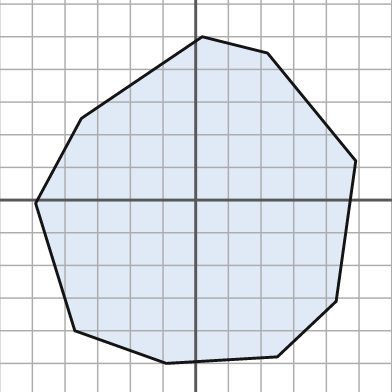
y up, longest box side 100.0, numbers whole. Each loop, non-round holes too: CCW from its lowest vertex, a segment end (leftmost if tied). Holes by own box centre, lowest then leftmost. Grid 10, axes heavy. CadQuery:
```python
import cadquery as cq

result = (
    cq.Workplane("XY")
    .moveTo(-9.0, -50.0)
    .lineTo(25.0, -48.0)
    .lineTo(43.0, -31.0)
    .lineTo(49.0, 12.0)
    .lineTo(22.0, 45.0)
    .lineTo(2.0, 50.0)
    .lineTo(-35.0, 25.0)
    .lineTo(-49.0, -1.0)
    .lineTo(-37.0, -40.0)
    .close()
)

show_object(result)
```